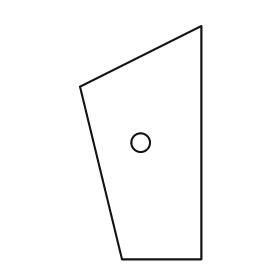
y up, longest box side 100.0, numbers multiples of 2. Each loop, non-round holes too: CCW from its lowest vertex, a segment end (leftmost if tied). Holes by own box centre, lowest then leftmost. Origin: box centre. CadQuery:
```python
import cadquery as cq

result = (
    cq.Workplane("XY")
    .moveTo(-8.0, -50.0)
    .lineTo(26.0, -50.0)
    .lineTo(26.0, 50.0)
    .lineTo(-26.0, 24.0)
    .close()
    .moveTo(0.0, 0.0)
    .circle(4.0)
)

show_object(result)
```